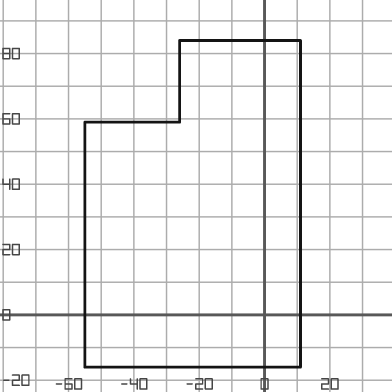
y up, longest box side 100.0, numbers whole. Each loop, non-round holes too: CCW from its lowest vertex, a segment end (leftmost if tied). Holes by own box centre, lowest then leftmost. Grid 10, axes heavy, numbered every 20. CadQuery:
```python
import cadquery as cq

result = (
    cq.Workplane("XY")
    .moveTo(-55.0, -16.0)
    .lineTo(11.0, -16.0)
    .lineTo(11.0, 84.0)
    .lineTo(-26.0, 84.0)
    .lineTo(-26.0, 59.0)
    .lineTo(-55.0, 59.0)
    .close()
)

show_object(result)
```